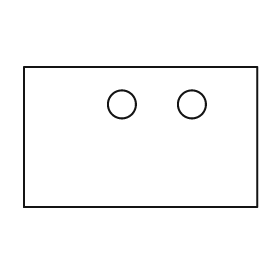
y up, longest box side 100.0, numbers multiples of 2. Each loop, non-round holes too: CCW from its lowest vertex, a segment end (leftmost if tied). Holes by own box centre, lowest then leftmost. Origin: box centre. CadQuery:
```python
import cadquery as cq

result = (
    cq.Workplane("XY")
    .moveTo(-50.0, -30.0)
    .lineTo(50.0, -30.0)
    .lineTo(50.0, 30.0)
    .lineTo(-50.0, 30.0)
    .close()
    .moveTo(-8.0, 14.0)
    .circle(6.0)
    .moveTo(22.0, 14.0)
    .circle(6.0)
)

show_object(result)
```